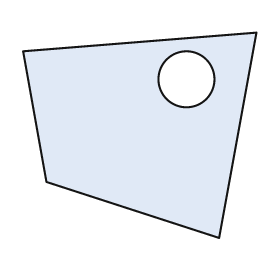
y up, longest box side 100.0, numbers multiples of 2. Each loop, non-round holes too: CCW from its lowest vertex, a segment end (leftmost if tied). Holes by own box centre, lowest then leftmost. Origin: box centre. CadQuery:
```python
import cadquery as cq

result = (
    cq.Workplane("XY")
    .moveTo(34.0, -44.0)
    .lineTo(50.0, 44.0)
    .lineTo(-50.0, 36.0)
    .lineTo(-40.0, -20.0)
    .close()
    .moveTo(20.0, 24.0)
    .circle(12.0)
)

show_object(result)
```